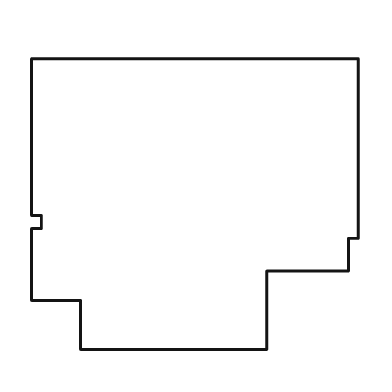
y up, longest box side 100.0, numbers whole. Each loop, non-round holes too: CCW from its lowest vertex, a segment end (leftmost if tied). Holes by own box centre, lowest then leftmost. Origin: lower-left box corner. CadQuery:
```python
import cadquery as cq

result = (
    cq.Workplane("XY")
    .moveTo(15.0, 0.0)
    .lineTo(72.0, 0.0)
    .lineTo(72.0, 24.0)
    .lineTo(97.0, 24.0)
    .lineTo(97.0, 34.0)
    .lineTo(100.0, 34.0)
    .lineTo(100.0, 89.0)
    .lineTo(0.0, 89.0)
    .lineTo(0.0, 41.0)
    .lineTo(3.0, 41.0)
    .lineTo(3.0, 37.0)
    .lineTo(0.0, 37.0)
    .lineTo(0.0, 15.0)
    .lineTo(15.0, 15.0)
    .close()
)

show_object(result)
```